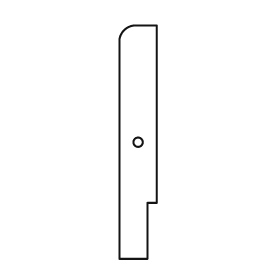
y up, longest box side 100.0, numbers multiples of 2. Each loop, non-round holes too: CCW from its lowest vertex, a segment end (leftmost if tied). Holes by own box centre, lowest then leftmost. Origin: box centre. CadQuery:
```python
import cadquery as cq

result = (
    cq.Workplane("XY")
    .moveTo(-8.0, -50.0)
    .lineTo(4.0, -50.0)
    .lineTo(4.0, -26.0)
    .lineTo(8.0, -26.0)
    .lineTo(8.0, 50.0)
    .lineTo(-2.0, 50.0)
    .threePointArc((-6.0, 48.0), (-8.0, 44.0))
    .close()
    .moveTo(0.0, 0.0)
    .circle(2.0)
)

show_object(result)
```